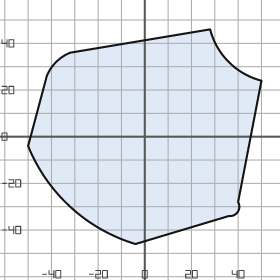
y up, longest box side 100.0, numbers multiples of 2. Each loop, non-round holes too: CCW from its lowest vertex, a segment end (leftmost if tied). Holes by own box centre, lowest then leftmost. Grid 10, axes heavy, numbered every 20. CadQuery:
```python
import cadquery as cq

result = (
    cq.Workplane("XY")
    .moveTo(-4.0, -46.0)
    .lineTo(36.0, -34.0)
    .threePointArc((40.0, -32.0), (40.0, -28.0))
    .lineTo(50.0, 24.0)
    .threePointArc((36.0, 32.0), (28.0, 46.0))
    .lineTo(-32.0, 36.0)
    .threePointArc((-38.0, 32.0), (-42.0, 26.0))
    .lineTo(-50.0, -4.0)
    .threePointArc((-32.0, -30.0), (-4.0, -46.0))
    .close()
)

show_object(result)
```